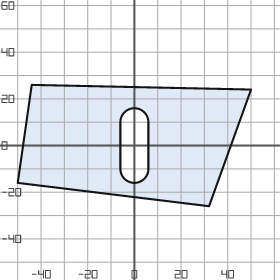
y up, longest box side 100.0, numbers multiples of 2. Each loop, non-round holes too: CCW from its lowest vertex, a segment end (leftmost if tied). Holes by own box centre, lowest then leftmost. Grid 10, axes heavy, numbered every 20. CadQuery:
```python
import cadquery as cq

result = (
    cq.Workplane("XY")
    .moveTo(32.0, -26.0)
    .lineTo(50.0, 24.0)
    .lineTo(-44.0, 26.0)
    .lineTo(-50.0, -16.0)
    .close()
    .moveTo(-6.0, -10.0)
    .threePointArc((0.0, -16.0), (6.0, -10.0))
    .lineTo(6.0, 10.0)
    .threePointArc((0.0, 16.0), (-6.0, 10.0))
    .close()
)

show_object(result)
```